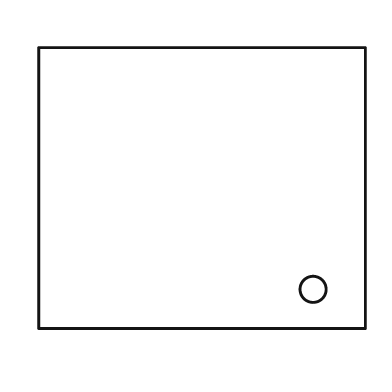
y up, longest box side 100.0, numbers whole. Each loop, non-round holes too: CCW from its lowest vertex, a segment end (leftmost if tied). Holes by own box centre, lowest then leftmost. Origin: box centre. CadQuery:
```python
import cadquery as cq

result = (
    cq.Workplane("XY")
    .moveTo(-50.0, -43.0)
    .lineTo(50.0, -43.0)
    .lineTo(50.0, 43.0)
    .lineTo(-50.0, 43.0)
    .close()
    .moveTo(34.0, -31.0)
    .circle(4.0)
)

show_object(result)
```